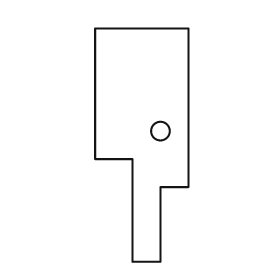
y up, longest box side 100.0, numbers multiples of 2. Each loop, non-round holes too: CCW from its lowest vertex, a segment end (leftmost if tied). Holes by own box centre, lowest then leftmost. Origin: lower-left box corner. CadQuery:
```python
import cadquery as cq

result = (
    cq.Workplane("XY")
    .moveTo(16.0, 0.0)
    .lineTo(28.0, 0.0)
    .lineTo(28.0, 32.0)
    .lineTo(40.0, 32.0)
    .lineTo(40.0, 100.0)
    .lineTo(0.0, 100.0)
    .lineTo(0.0, 44.0)
    .lineTo(16.0, 44.0)
    .close()
    .moveTo(28.0, 56.0)
    .circle(4.0)
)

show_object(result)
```